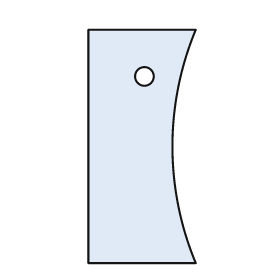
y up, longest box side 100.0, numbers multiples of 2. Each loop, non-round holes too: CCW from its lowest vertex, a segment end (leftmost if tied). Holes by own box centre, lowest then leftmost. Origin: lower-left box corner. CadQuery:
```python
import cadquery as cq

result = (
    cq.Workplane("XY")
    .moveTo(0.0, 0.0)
    .lineTo(46.0, 0.0)
    .threePointArc((36.0, 50.0), (46.0, 100.0))
    .lineTo(0.0, 100.0)
    .close()
    .moveTo(24.0, 80.0)
    .circle(4.0)
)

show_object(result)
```